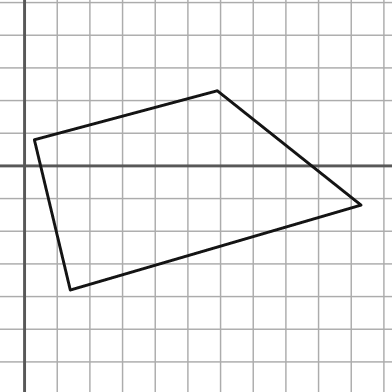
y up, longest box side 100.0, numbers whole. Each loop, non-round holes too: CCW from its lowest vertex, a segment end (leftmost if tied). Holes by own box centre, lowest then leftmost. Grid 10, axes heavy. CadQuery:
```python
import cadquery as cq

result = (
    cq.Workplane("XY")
    .moveTo(14.0, -38.0)
    .lineTo(103.0, -12.0)
    .lineTo(59.0, 23.0)
    .lineTo(3.0, 8.0)
    .close()
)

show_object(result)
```